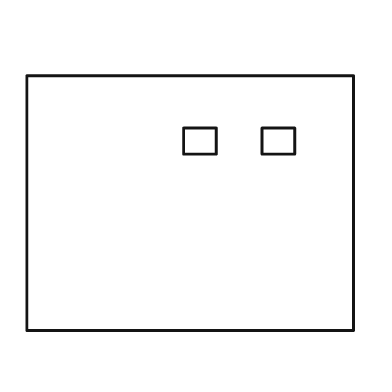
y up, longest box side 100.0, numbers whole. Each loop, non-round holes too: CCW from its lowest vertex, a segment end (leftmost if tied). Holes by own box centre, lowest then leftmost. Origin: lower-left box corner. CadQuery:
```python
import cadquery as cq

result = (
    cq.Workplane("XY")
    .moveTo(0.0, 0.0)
    .lineTo(100.0, 0.0)
    .lineTo(100.0, 78.0)
    .lineTo(0.0, 78.0)
    .close()
    .moveTo(48.0, 54.0)
    .lineTo(58.0, 54.0)
    .lineTo(58.0, 62.0)
    .lineTo(48.0, 62.0)
    .close()
    .moveTo(72.0, 54.0)
    .lineTo(82.0, 54.0)
    .lineTo(82.0, 62.0)
    .lineTo(72.0, 62.0)
    .close()
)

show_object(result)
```